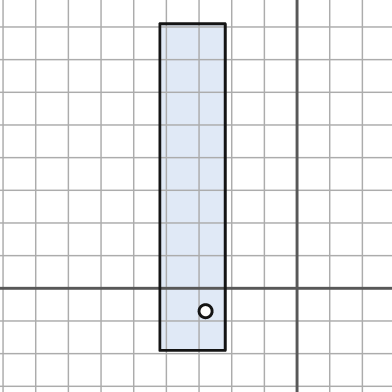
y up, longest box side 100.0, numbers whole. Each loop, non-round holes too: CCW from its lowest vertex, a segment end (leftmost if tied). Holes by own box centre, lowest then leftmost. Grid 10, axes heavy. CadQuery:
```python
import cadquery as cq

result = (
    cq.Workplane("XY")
    .moveTo(-42.0, -19.0)
    .lineTo(-22.0, -19.0)
    .lineTo(-22.0, 81.0)
    .lineTo(-42.0, 81.0)
    .close()
    .moveTo(-28.0, -7.0)
    .circle(2.0)
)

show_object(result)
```